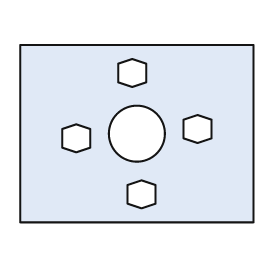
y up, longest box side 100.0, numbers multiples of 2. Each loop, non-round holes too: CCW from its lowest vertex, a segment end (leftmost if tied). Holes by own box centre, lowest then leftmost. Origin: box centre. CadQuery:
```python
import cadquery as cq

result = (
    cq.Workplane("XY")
    .moveTo(-50.0, -38.0)
    .lineTo(50.0, -38.0)
    .lineTo(50.0, 38.0)
    .lineTo(-50.0, 38.0)
    .close()
    .moveTo(2.0, -32.0)
    .lineTo(8.0, -30.0)
    .lineTo(8.0, -22.0)
    .lineTo(2.0, -20.0)
    .lineTo(-4.0, -22.0)
    .lineTo(-4.0, -30.0)
    .close()
    .moveTo(-26.0, -8.0)
    .lineTo(-20.0, -6.0)
    .lineTo(-20.0, 2.0)
    .lineTo(-26.0, 4.0)
    .lineTo(-32.0, 2.0)
    .lineTo(-32.0, -6.0)
    .close()
    .moveTo(0.0, 0.0)
    .circle(12.0)
    .moveTo(26.0, -4.0)
    .lineTo(32.0, -2.0)
    .lineTo(32.0, 6.0)
    .lineTo(26.0, 8.0)
    .lineTo(20.0, 6.0)
    .lineTo(20.0, -2.0)
    .close()
    .moveTo(-2.0, 20.0)
    .lineTo(4.0, 22.0)
    .lineTo(4.0, 30.0)
    .lineTo(-2.0, 32.0)
    .lineTo(-8.0, 30.0)
    .lineTo(-8.0, 22.0)
    .close()
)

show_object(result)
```